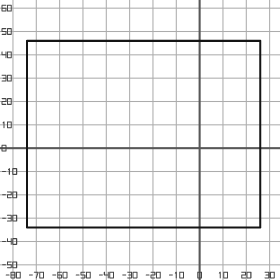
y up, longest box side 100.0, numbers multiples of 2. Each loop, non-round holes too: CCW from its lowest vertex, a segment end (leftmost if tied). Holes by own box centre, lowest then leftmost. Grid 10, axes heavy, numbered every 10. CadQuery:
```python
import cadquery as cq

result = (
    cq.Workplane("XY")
    .moveTo(-74.0, -34.0)
    .lineTo(26.0, -34.0)
    .lineTo(26.0, 46.0)
    .lineTo(-74.0, 46.0)
    .close()
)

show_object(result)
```